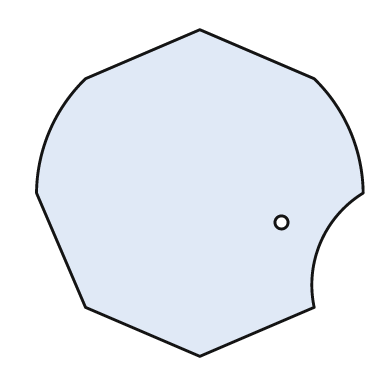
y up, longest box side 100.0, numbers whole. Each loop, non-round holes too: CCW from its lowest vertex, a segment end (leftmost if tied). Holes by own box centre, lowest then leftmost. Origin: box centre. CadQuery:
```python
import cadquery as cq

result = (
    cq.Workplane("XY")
    .moveTo(0.0, -50.0)
    .lineTo(35.0, -35.0)
    .threePointArc((37.0, -15.0), (50.0, 0.0))
    .threePointArc((46.0, 19.0), (35.0, 35.0))
    .lineTo(0.0, 50.0)
    .lineTo(-35.0, 35.0)
    .threePointArc((-46.0, 19.0), (-50.0, 0.0))
    .lineTo(-35.0, -35.0)
    .close()
    .moveTo(25.0, -9.0)
    .circle(2.0)
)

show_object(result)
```